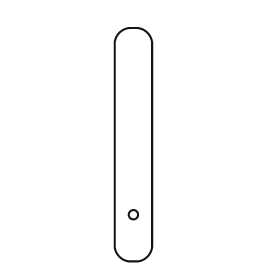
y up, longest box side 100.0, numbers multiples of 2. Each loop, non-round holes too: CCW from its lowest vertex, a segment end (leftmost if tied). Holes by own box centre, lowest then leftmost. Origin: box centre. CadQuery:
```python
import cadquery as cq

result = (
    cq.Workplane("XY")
    .moveTo(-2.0, -50.0)
    .lineTo(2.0, -50.0)
    .threePointArc((6.0, -48.0), (8.0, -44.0))
    .lineTo(8.0, 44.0)
    .threePointArc((6.0, 48.0), (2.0, 50.0))
    .lineTo(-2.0, 50.0)
    .threePointArc((-6.0, 48.0), (-8.0, 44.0))
    .lineTo(-8.0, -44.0)
    .threePointArc((-6.0, -48.0), (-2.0, -50.0))
    .close()
    .moveTo(0.0, -30.0)
    .circle(2.0)
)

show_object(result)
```